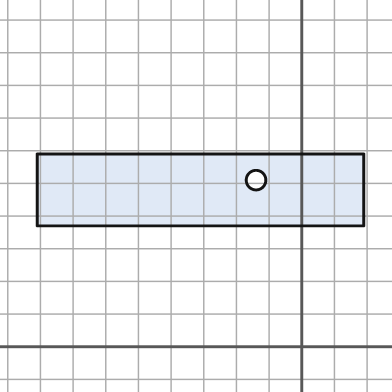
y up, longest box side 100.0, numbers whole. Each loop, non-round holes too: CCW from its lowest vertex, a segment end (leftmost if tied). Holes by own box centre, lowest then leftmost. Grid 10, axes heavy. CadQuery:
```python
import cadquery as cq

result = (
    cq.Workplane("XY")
    .moveTo(-81.0, 37.0)
    .lineTo(19.0, 37.0)
    .lineTo(19.0, 59.0)
    .lineTo(-81.0, 59.0)
    .close()
    .moveTo(-14.0, 51.0)
    .circle(3.0)
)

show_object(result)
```